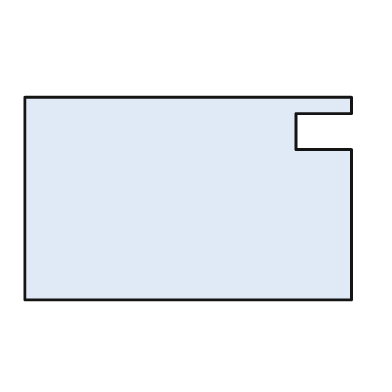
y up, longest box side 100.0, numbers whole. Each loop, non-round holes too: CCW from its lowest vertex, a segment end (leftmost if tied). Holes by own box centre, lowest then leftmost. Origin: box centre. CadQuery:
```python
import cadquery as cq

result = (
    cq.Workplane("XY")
    .moveTo(-50.0, -31.0)
    .lineTo(50.0, -31.0)
    .lineTo(50.0, 15.0)
    .lineTo(33.0, 15.0)
    .lineTo(33.0, 26.0)
    .lineTo(50.0, 26.0)
    .lineTo(50.0, 31.0)
    .lineTo(-50.0, 31.0)
    .close()
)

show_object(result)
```